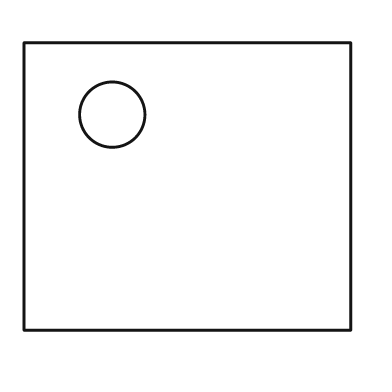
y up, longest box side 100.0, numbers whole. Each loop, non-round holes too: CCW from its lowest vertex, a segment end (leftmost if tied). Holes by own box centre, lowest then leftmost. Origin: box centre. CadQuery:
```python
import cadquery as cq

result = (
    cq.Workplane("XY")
    .moveTo(-50.0, -44.0)
    .lineTo(50.0, -44.0)
    .lineTo(50.0, 44.0)
    .lineTo(-50.0, 44.0)
    .close()
    .moveTo(-23.0, 22.0)
    .circle(10.0)
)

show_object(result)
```